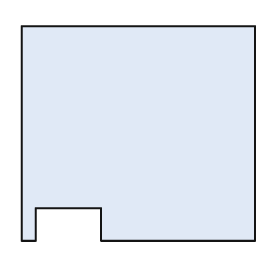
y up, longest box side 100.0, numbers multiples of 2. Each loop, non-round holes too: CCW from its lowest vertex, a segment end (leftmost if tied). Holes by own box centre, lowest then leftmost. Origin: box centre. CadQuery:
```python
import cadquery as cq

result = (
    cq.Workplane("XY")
    .moveTo(-50.0, -46.0)
    .lineTo(-44.0, -46.0)
    .lineTo(-44.0, -32.0)
    .lineTo(-16.0, -32.0)
    .lineTo(-16.0, -46.0)
    .lineTo(50.0, -46.0)
    .lineTo(50.0, 46.0)
    .lineTo(-50.0, 46.0)
    .close()
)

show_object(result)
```